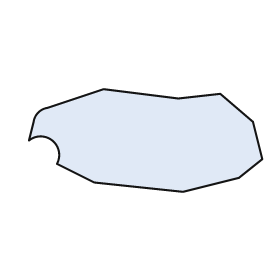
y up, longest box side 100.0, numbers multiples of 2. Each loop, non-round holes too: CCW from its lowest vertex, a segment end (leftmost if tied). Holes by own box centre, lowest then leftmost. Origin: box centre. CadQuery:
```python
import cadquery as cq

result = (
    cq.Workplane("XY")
    .moveTo(16.0, -22.0)
    .lineTo(40.0, -16.0)
    .lineTo(50.0, -8.0)
    .lineTo(46.0, 8.0)
    .lineTo(32.0, 20.0)
    .lineTo(14.0, 18.0)
    .lineTo(-18.0, 22.0)
    .lineTo(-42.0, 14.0)
    .threePointArc((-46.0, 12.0), (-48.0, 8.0))
    .lineTo(-50.0, 0.0)
    .threePointArc((-40.0, 0.0), (-38.0, -10.0))
    .lineTo(-22.0, -18.0)
    .close()
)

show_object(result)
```